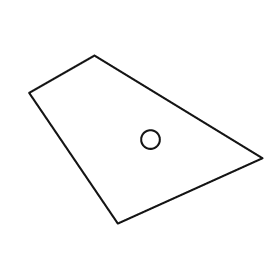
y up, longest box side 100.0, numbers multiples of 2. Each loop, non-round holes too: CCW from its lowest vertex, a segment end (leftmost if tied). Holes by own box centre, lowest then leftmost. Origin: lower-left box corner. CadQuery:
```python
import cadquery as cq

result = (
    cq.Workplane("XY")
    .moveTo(38.0, 0.0)
    .lineTo(100.0, 28.0)
    .lineTo(28.0, 72.0)
    .lineTo(0.0, 56.0)
    .close()
    .moveTo(52.0, 36.0)
    .circle(4.0)
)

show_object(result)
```